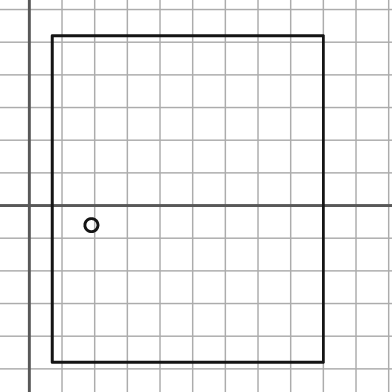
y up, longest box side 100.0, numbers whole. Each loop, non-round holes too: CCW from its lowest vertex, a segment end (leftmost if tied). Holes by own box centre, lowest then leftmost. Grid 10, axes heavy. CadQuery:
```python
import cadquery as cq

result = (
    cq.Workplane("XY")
    .moveTo(7.0, -48.0)
    .lineTo(90.0, -48.0)
    .lineTo(90.0, 52.0)
    .lineTo(7.0, 52.0)
    .close()
    .moveTo(19.0, -6.0)
    .circle(2.0)
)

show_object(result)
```